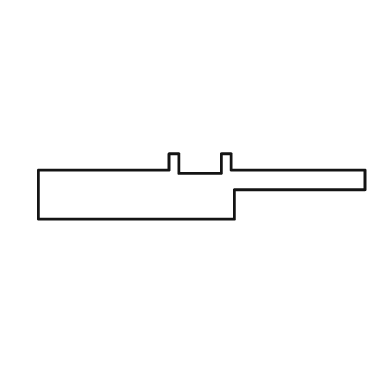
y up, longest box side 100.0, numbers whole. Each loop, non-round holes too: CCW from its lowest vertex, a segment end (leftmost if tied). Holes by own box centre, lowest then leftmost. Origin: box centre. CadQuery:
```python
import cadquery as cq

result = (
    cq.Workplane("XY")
    .moveTo(-50.0, -10.0)
    .lineTo(10.0, -10.0)
    .lineTo(10.0, -1.0)
    .lineTo(50.0, -1.0)
    .lineTo(50.0, 5.0)
    .lineTo(9.0, 5.0)
    .lineTo(9.0, 10.0)
    .lineTo(6.0, 10.0)
    .lineTo(6.0, 4.0)
    .lineTo(-7.0, 4.0)
    .lineTo(-7.0, 10.0)
    .lineTo(-10.0, 10.0)
    .lineTo(-10.0, 5.0)
    .lineTo(-50.0, 5.0)
    .close()
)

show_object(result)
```